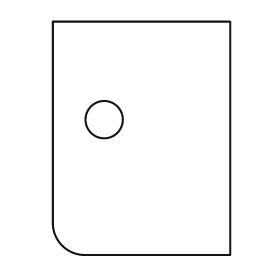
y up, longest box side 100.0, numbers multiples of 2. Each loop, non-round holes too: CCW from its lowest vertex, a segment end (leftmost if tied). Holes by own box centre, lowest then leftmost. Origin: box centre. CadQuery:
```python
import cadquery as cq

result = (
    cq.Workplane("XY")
    .moveTo(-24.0, -50.0)
    .lineTo(38.0, -50.0)
    .lineTo(38.0, 50.0)
    .lineTo(-38.0, 50.0)
    .lineTo(-38.0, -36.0)
    .threePointArc((-34.0, -46.0), (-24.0, -50.0))
    .close()
    .moveTo(-16.0, 8.0)
    .circle(8.0)
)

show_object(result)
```